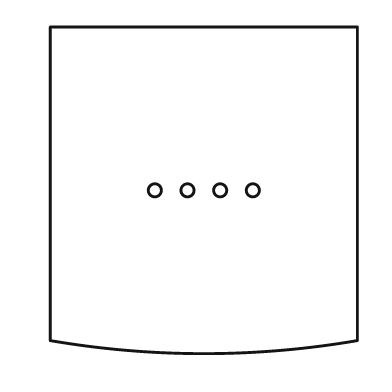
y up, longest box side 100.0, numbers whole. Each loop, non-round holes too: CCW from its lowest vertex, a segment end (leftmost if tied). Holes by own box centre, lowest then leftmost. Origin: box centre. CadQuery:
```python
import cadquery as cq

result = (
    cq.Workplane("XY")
    .moveTo(-47.0, -46.0)
    .threePointArc((0.0, -50.0), (47.0, -46.0))
    .lineTo(47.0, 50.0)
    .lineTo(-47.0, 50.0)
    .close()
    .moveTo(-15.0, 0.0)
    .circle(2.0)
    .moveTo(-5.0, 0.0)
    .circle(2.0)
    .moveTo(5.0, 0.0)
    .circle(2.0)
    .moveTo(15.0, 0.0)
    .circle(2.0)
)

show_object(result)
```